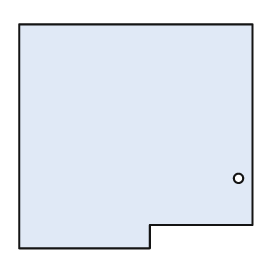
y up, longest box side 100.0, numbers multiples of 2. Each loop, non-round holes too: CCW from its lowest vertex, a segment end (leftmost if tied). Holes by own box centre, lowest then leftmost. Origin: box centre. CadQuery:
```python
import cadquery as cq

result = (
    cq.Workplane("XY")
    .moveTo(-50.0, -48.0)
    .lineTo(6.0, -48.0)
    .lineTo(6.0, -38.0)
    .lineTo(50.0, -38.0)
    .lineTo(50.0, 48.0)
    .lineTo(-50.0, 48.0)
    .close()
    .moveTo(44.0, -18.0)
    .circle(2.0)
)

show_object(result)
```